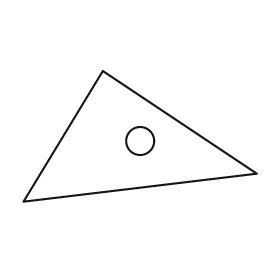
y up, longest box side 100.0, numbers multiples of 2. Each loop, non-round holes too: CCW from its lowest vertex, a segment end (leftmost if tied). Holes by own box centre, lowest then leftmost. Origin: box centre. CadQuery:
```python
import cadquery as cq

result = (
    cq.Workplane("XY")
    .moveTo(-50.0, -28.0)
    .lineTo(50.0, -16.0)
    .lineTo(-16.0, 28.0)
    .close()
    .moveTo(0.0, -2.0)
    .circle(6.0)
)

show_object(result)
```